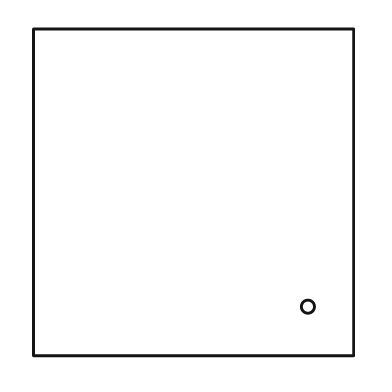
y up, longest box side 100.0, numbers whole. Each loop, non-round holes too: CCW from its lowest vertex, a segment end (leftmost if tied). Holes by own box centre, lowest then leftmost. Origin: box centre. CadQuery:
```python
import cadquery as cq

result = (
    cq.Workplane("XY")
    .moveTo(-49.0, -50.0)
    .lineTo(49.0, -50.0)
    .lineTo(49.0, 50.0)
    .lineTo(-49.0, 50.0)
    .close()
    .moveTo(35.0, -35.0)
    .circle(2.0)
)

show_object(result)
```